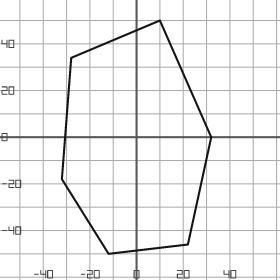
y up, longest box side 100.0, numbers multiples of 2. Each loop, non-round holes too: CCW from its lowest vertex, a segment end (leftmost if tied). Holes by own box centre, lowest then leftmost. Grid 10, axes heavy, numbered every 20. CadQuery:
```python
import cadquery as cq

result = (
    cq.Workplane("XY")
    .moveTo(-12.0, -50.0)
    .lineTo(22.0, -46.0)
    .lineTo(32.0, 0.0)
    .lineTo(10.0, 50.0)
    .lineTo(-28.0, 34.0)
    .lineTo(-32.0, -18.0)
    .close()
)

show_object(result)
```